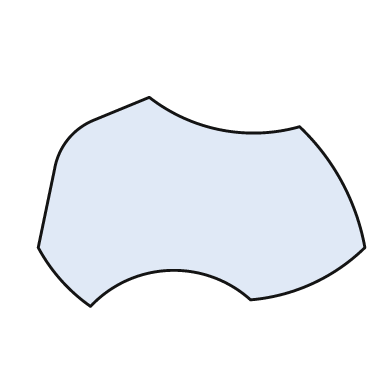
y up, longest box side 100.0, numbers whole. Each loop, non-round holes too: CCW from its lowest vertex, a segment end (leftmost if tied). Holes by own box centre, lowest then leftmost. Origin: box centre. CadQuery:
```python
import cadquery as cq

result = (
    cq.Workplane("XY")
    .moveTo(-34.0, -32.0)
    .threePointArc((-10.0, -21.0), (15.0, -30.0))
    .threePointArc((34.0, -25.0), (50.0, -14.0))
    .threePointArc((43.0, 6.0), (30.0, 23.0))
    .threePointArc((6.0, 22.0), (-16.0, 32.0))
    .lineTo(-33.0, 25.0)
    .threePointArc((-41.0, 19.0), (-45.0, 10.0))
    .lineTo(-50.0, -14.0)
    .threePointArc((-43.0, -24.0), (-34.0, -32.0))
    .close()
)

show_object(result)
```